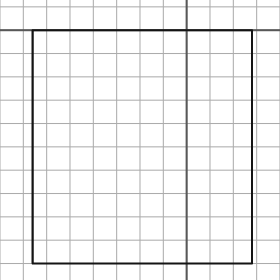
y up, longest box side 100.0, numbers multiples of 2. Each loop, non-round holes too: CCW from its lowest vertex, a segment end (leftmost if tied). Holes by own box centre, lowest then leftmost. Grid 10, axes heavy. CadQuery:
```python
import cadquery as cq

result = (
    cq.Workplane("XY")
    .moveTo(-66.0, -100.0)
    .lineTo(28.0, -100.0)
    .lineTo(28.0, 0.0)
    .lineTo(-66.0, 0.0)
    .close()
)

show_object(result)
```